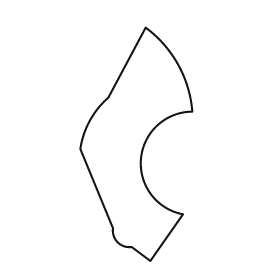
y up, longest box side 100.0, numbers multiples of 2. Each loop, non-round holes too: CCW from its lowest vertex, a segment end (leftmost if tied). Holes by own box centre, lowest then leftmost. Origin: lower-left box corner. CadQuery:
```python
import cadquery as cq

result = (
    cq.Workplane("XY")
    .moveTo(30.0, 0.0)
    .lineTo(44.0, 20.0)
    .threePointArc((26.0, 44.0), (48.0, 64.0))
    .threePointArc((42.0, 84.0), (28.0, 100.0))
    .lineTo(12.0, 70.0)
    .threePointArc((4.0, 60.0), (0.0, 48.0))
    .lineTo(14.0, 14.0)
    .threePointArc((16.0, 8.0), (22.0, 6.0))
    .close()
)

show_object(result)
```